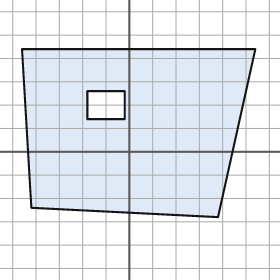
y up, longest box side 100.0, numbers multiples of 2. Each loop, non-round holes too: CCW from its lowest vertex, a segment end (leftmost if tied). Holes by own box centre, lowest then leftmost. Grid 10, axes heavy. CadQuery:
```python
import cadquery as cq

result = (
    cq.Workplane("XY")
    .moveTo(38.0, -28.0)
    .lineTo(54.0, 44.0)
    .lineTo(-46.0, 44.0)
    .lineTo(-42.0, -24.0)
    .close()
    .moveTo(-18.0, 14.0)
    .lineTo(-2.0, 14.0)
    .lineTo(-2.0, 26.0)
    .lineTo(-18.0, 26.0)
    .close()
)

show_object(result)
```